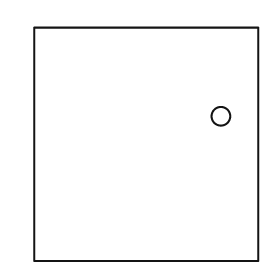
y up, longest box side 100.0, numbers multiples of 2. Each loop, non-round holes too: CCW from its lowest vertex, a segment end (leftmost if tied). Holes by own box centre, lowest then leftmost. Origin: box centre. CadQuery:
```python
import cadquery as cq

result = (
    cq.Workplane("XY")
    .moveTo(-48.0, -50.0)
    .lineTo(48.0, -50.0)
    .lineTo(48.0, 50.0)
    .lineTo(-48.0, 50.0)
    .close()
    .moveTo(32.0, 12.0)
    .circle(4.0)
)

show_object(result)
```